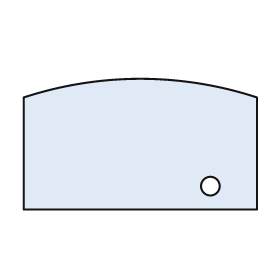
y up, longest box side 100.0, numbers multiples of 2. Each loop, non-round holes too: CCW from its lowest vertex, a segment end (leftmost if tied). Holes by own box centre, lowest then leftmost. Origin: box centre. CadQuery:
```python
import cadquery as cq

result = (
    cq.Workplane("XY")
    .moveTo(-50.0, -28.0)
    .lineTo(50.0, -28.0)
    .lineTo(50.0, 20.0)
    .threePointArc((0.0, 28.0), (-50.0, 20.0))
    .close()
    .moveTo(30.0, -18.0)
    .circle(4.0)
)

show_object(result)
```